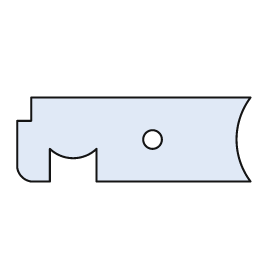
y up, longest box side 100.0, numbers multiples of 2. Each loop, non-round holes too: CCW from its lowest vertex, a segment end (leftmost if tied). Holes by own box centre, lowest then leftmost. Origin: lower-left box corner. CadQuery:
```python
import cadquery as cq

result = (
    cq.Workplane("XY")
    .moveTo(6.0, 0.0)
    .lineTo(14.0, 0.0)
    .lineTo(14.0, 14.0)
    .threePointArc((24.0, 10.0), (34.0, 14.0))
    .lineTo(34.0, 0.0)
    .lineTo(100.0, 0.0)
    .threePointArc((94.0, 18.0), (100.0, 36.0))
    .lineTo(6.0, 36.0)
    .lineTo(6.0, 26.0)
    .lineTo(0.0, 26.0)
    .lineTo(0.0, 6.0)
    .threePointArc((2.0, 2.0), (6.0, 0.0))
    .close()
    .moveTo(58.0, 18.0)
    .circle(4.0)
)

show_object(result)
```